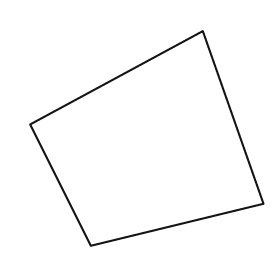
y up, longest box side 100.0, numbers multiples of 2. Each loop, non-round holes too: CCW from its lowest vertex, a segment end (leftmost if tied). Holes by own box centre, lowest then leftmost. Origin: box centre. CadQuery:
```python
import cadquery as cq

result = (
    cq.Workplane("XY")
    .moveTo(-24.0, -46.0)
    .lineTo(50.0, -28.0)
    .lineTo(24.0, 46.0)
    .lineTo(-50.0, 6.0)
    .close()
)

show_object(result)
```